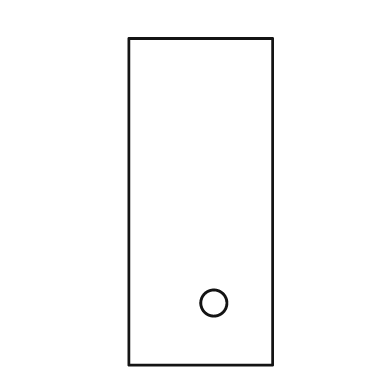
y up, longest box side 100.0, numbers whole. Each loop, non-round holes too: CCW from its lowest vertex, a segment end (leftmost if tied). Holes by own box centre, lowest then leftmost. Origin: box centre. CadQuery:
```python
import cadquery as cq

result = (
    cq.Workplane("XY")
    .moveTo(-22.0, -50.0)
    .lineTo(22.0, -50.0)
    .lineTo(22.0, 50.0)
    .lineTo(-22.0, 50.0)
    .close()
    .moveTo(4.0, -31.0)
    .circle(4.0)
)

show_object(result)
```